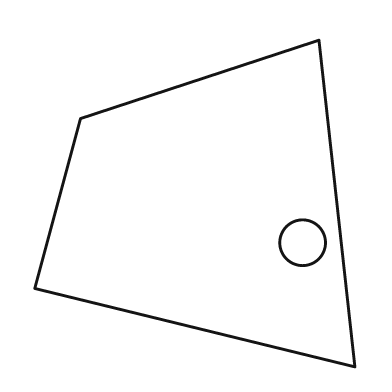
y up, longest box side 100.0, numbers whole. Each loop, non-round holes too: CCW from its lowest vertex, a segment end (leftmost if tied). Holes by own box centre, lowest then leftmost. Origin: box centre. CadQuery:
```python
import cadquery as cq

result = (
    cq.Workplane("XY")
    .moveTo(49.0, -50.0)
    .lineTo(38.0, 50.0)
    .lineTo(-35.0, 26.0)
    .lineTo(-49.0, -26.0)
    .close()
    .moveTo(33.0, -12.0)
    .circle(7.0)
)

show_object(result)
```